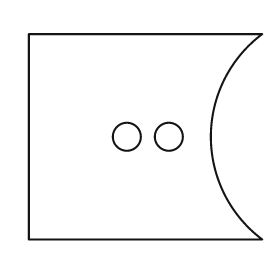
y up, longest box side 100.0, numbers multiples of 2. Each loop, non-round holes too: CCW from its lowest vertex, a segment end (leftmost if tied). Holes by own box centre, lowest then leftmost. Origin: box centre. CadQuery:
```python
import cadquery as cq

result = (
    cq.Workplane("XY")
    .moveTo(-50.0, -44.0)
    .lineTo(50.0, -44.0)
    .threePointArc((28.0, 0.0), (50.0, 44.0))
    .lineTo(-50.0, 44.0)
    .close()
    .moveTo(-8.0, 0.0)
    .circle(6.0)
    .moveTo(10.0, 0.0)
    .circle(6.0)
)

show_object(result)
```